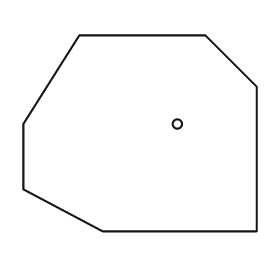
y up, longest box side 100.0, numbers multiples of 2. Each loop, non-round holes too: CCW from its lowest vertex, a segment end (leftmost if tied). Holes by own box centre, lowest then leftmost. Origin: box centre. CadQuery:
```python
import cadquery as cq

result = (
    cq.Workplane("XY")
    .moveTo(-16.0, -42.0)
    .lineTo(50.0, -42.0)
    .lineTo(50.0, 20.0)
    .lineTo(28.0, 42.0)
    .lineTo(-26.0, 42.0)
    .lineTo(-50.0, 4.0)
    .lineTo(-50.0, -24.0)
    .close()
    .moveTo(16.0, 4.0)
    .circle(2.0)
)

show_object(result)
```